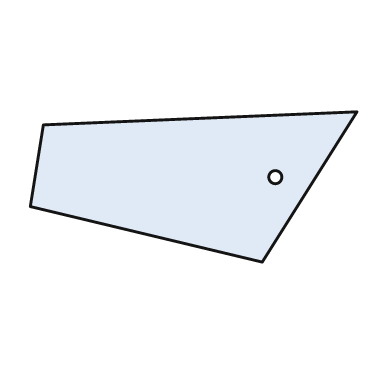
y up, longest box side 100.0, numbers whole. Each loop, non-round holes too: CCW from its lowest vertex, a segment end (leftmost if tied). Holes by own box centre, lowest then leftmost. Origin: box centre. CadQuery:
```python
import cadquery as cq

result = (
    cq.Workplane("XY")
    .moveTo(21.0, -23.0)
    .lineTo(50.0, 23.0)
    .lineTo(-46.0, 19.0)
    .lineTo(-50.0, -6.0)
    .close()
    .moveTo(25.0, 3.0)
    .circle(2.0)
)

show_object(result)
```